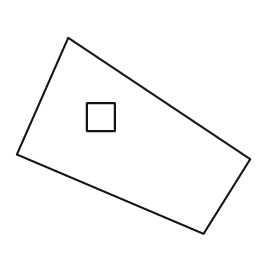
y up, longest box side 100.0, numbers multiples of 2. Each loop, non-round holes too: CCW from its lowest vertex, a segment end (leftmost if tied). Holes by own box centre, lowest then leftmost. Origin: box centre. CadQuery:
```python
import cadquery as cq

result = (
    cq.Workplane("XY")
    .moveTo(30.0, -42.0)
    .lineTo(50.0, -10.0)
    .lineTo(-28.0, 42.0)
    .lineTo(-50.0, -8.0)
    .close()
    .moveTo(-20.0, 2.0)
    .lineTo(-8.0, 2.0)
    .lineTo(-8.0, 14.0)
    .lineTo(-20.0, 14.0)
    .close()
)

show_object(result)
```